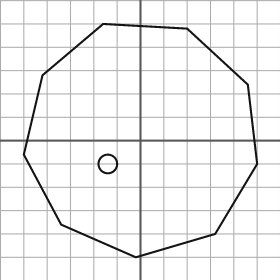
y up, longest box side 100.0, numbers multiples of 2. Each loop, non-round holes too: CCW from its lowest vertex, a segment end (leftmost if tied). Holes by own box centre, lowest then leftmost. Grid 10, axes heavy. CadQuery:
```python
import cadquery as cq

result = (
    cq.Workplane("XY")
    .moveTo(-2.0, -50.0)
    .lineTo(32.0, -40.0)
    .lineTo(50.0, -10.0)
    .lineTo(46.0, 24.0)
    .lineTo(20.0, 48.0)
    .lineTo(-16.0, 50.0)
    .lineTo(-42.0, 28.0)
    .lineTo(-50.0, -6.0)
    .lineTo(-34.0, -36.0)
    .close()
    .moveTo(-14.0, -10.0)
    .circle(4.0)
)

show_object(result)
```